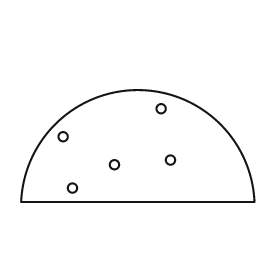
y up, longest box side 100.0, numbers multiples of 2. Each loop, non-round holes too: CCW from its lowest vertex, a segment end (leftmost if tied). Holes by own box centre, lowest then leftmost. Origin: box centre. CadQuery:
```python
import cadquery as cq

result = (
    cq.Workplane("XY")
    .moveTo(-50.0, -24.0)
    .lineTo(50.0, -24.0)
    .threePointArc((0.0, 24.0), (-50.0, -24.0))
    .close()
    .moveTo(-28.0, -18.0)
    .circle(2.0)
    .moveTo(-10.0, -8.0)
    .circle(2.0)
    .moveTo(14.0, -6.0)
    .circle(2.0)
    .moveTo(-32.0, 4.0)
    .circle(2.0)
    .moveTo(10.0, 16.0)
    .circle(2.0)
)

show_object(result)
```